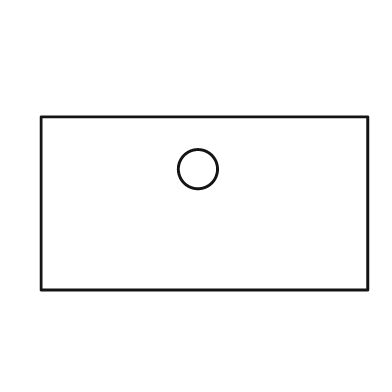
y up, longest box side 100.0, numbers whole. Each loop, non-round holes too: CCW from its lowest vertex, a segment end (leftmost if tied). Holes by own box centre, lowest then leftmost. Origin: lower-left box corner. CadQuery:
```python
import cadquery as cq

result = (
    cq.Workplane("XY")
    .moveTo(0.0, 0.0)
    .lineTo(100.0, 0.0)
    .lineTo(100.0, 53.0)
    .lineTo(0.0, 53.0)
    .close()
    .moveTo(48.0, 37.0)
    .circle(6.0)
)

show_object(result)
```